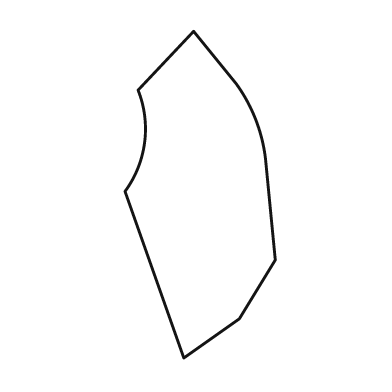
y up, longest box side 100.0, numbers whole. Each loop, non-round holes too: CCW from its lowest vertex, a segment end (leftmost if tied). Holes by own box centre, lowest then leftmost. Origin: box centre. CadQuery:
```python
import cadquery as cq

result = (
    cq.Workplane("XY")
    .moveTo(-5.0, -50.0)
    .lineTo(12.0, -38.0)
    .lineTo(23.0, -20.0)
    .lineTo(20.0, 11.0)
    .threePointArc((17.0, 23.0), (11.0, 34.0))
    .lineTo(-2.0, 50.0)
    .lineTo(-19.0, 32.0)
    .threePointArc((-17.0, 16.0), (-23.0, 1.0))
    .close()
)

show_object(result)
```